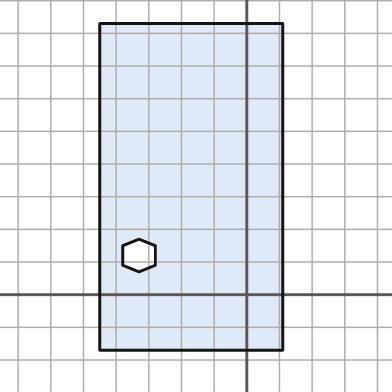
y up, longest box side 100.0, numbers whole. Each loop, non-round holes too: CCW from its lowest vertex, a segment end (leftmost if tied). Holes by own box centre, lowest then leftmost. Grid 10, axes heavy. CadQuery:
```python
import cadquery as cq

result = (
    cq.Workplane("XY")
    .moveTo(-45.0, -17.0)
    .lineTo(11.0, -17.0)
    .lineTo(11.0, 83.0)
    .lineTo(-45.0, 83.0)
    .close()
    .moveTo(-33.0, 7.0)
    .lineTo(-28.0, 9.0)
    .lineTo(-28.0, 15.0)
    .lineTo(-33.0, 17.0)
    .lineTo(-38.0, 15.0)
    .lineTo(-38.0, 9.0)
    .close()
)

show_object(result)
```